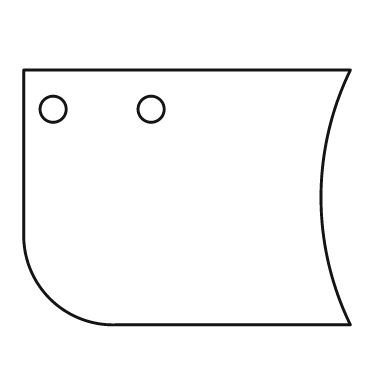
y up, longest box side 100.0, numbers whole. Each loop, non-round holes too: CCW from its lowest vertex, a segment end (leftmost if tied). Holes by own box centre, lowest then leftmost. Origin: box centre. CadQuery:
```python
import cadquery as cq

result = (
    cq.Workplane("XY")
    .moveTo(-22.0, -39.0)
    .lineTo(50.0, -39.0)
    .threePointArc((41.0, 0.0), (50.0, 39.0))
    .lineTo(-50.0, 39.0)
    .lineTo(-50.0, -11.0)
    .threePointArc((-42.0, -31.0), (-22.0, -39.0))
    .close()
    .moveTo(-41.0, 27.0)
    .circle(4.0)
    .moveTo(-11.0, 27.0)
    .circle(4.0)
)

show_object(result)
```